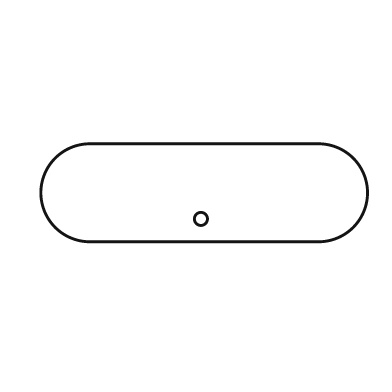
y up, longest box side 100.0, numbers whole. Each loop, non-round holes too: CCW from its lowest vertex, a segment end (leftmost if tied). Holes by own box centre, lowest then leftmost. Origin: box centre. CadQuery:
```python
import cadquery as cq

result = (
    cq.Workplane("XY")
    .moveTo(-35.0, -15.0)
    .lineTo(35.0, -15.0)
    .threePointArc((50.0, 0.0), (35.0, 15.0))
    .lineTo(-35.0, 15.0)
    .threePointArc((-50.0, 0.0), (-35.0, -15.0))
    .close()
    .moveTo(-1.0, -8.0)
    .circle(2.0)
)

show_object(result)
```